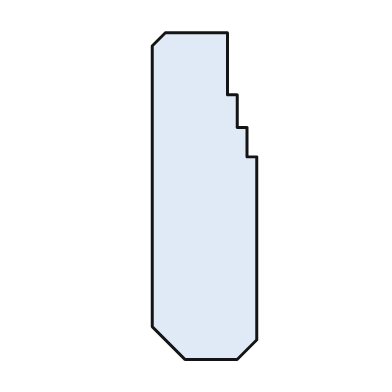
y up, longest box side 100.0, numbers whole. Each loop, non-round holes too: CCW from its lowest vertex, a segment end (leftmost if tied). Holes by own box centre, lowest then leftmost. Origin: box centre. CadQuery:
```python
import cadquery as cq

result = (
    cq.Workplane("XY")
    .moveTo(-6.0, -50.0)
    .lineTo(10.0, -50.0)
    .lineTo(16.0, -44.0)
    .lineTo(16.0, 12.0)
    .lineTo(13.0, 12.0)
    .lineTo(13.0, 21.0)
    .lineTo(10.0, 21.0)
    .lineTo(10.0, 31.0)
    .lineTo(7.0, 31.0)
    .lineTo(7.0, 50.0)
    .lineTo(-12.0, 50.0)
    .lineTo(-16.0, 46.0)
    .lineTo(-16.0, -40.0)
    .close()
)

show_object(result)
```